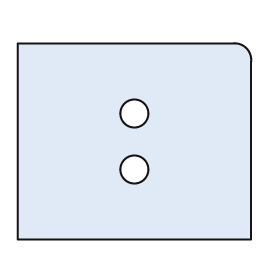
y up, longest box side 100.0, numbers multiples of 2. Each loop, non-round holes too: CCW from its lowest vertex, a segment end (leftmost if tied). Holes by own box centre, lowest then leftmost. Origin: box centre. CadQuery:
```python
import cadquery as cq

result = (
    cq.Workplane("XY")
    .moveTo(-50.0, -42.0)
    .lineTo(50.0, -42.0)
    .lineTo(50.0, 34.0)
    .threePointArc((48.0, 40.0), (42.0, 42.0))
    .lineTo(-50.0, 42.0)
    .close()
    .moveTo(0.0, -12.0)
    .circle(6.0)
    .moveTo(0.0, 12.0)
    .circle(6.0)
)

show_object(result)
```